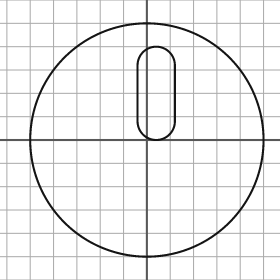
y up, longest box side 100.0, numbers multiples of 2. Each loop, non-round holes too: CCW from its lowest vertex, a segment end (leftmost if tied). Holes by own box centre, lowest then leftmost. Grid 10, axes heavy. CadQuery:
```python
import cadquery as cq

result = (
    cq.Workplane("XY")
    .moveTo(0.0, 0.0)
    .circle(50.0)
    .moveTo(-4.0, 8.0)
    .threePointArc((4.0, 0.0), (12.0, 8.0))
    .lineTo(12.0, 32.0)
    .threePointArc((4.0, 40.0), (-4.0, 32.0))
    .close()
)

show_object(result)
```